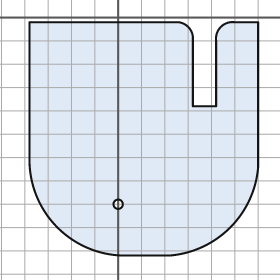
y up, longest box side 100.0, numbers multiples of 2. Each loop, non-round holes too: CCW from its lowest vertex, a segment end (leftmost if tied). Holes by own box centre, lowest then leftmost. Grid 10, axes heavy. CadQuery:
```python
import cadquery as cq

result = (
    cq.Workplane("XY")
    .moveTo(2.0, -102.0)
    .lineTo(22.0, -102.0)
    .threePointArc((48.0, -90.0), (60.0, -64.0))
    .lineTo(60.0, -2.0)
    .lineTo(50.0, -2.0)
    .threePointArc((44.0, -4.0), (42.0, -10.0))
    .lineTo(42.0, -38.0)
    .lineTo(32.0, -38.0)
    .lineTo(32.0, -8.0)
    .threePointArc((30.0, -4.0), (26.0, -2.0))
    .lineTo(-38.0, -2.0)
    .lineTo(-38.0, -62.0)
    .threePointArc((-26.0, -90.0), (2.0, -102.0))
    .close()
    .moveTo(0.0, -80.0)
    .circle(2.0)
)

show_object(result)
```